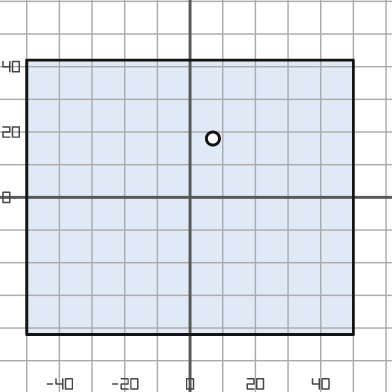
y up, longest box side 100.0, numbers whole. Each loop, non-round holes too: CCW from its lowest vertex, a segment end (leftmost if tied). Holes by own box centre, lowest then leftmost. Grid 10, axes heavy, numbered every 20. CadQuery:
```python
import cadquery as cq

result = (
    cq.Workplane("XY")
    .moveTo(-50.0, -42.0)
    .lineTo(50.0, -42.0)
    .lineTo(50.0, 42.0)
    .lineTo(-50.0, 42.0)
    .close()
    .moveTo(7.0, 18.0)
    .circle(2.0)
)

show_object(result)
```